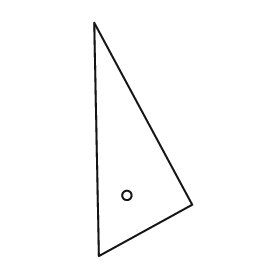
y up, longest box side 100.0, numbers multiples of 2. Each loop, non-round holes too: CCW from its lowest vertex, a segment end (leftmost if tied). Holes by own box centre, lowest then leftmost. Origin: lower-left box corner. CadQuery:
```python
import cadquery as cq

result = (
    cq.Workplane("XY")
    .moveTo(2.0, 0.0)
    .lineTo(42.0, 22.0)
    .lineTo(0.0, 100.0)
    .close()
    .moveTo(14.0, 26.0)
    .circle(2.0)
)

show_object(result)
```